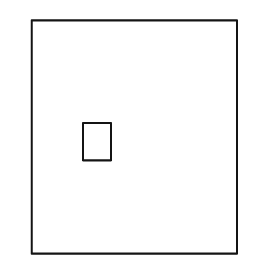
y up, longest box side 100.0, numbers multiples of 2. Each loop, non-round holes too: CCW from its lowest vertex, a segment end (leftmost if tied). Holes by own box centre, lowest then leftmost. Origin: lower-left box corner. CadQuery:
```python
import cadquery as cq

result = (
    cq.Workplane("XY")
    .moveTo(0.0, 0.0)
    .lineTo(88.0, 0.0)
    .lineTo(88.0, 100.0)
    .lineTo(0.0, 100.0)
    .close()
    .moveTo(22.0, 40.0)
    .lineTo(34.0, 40.0)
    .lineTo(34.0, 56.0)
    .lineTo(22.0, 56.0)
    .close()
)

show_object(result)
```